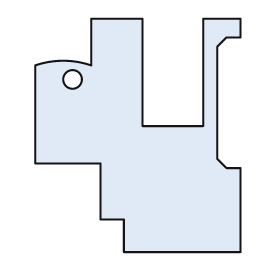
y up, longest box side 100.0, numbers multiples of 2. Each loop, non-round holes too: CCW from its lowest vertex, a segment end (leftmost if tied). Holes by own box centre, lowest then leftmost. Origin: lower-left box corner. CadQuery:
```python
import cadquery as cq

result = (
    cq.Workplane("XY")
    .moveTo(38.0, 0.0)
    .lineTo(88.0, 0.0)
    .lineTo(88.0, 36.0)
    .lineTo(82.0, 36.0)
    .lineTo(78.0, 40.0)
    .lineTo(78.0, 88.0)
    .lineTo(82.0, 92.0)
    .lineTo(88.0, 92.0)
    .lineTo(88.0, 100.0)
    .lineTo(72.0, 100.0)
    .lineTo(72.0, 54.0)
    .lineTo(46.0, 54.0)
    .lineTo(46.0, 100.0)
    .lineTo(24.0, 100.0)
    .lineTo(24.0, 80.0)
    .threePointArc((12.0, 82.0), (0.0, 80.0))
    .lineTo(0.0, 38.0)
    .lineTo(28.0, 38.0)
    .lineTo(28.0, 14.0)
    .lineTo(38.0, 14.0)
    .close()
    .moveTo(16.0, 74.0)
    .circle(4.0)
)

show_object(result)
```